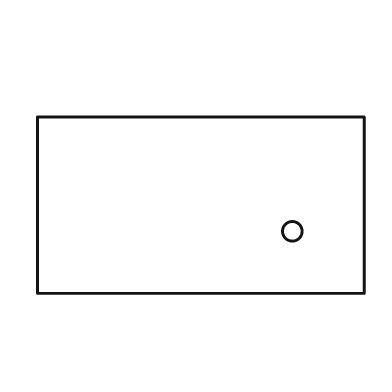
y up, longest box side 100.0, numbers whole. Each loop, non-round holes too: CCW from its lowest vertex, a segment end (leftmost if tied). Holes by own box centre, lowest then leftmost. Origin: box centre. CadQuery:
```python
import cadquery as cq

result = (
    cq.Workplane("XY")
    .moveTo(-50.0, -27.0)
    .lineTo(50.0, -27.0)
    .lineTo(50.0, 27.0)
    .lineTo(-50.0, 27.0)
    .close()
    .moveTo(28.0, -8.0)
    .circle(3.0)
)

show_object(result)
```